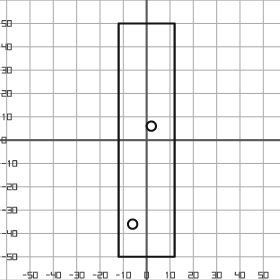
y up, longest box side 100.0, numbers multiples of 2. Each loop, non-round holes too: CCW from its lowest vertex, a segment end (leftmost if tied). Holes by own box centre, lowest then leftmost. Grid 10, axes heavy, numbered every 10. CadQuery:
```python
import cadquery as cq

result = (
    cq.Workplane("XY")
    .moveTo(-12.0, -50.0)
    .lineTo(12.0, -50.0)
    .lineTo(12.0, 50.0)
    .lineTo(-12.0, 50.0)
    .close()
    .moveTo(-6.0, -36.0)
    .circle(2.0)
    .moveTo(2.0, 6.0)
    .circle(2.0)
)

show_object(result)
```